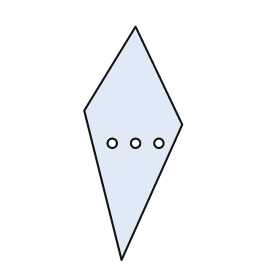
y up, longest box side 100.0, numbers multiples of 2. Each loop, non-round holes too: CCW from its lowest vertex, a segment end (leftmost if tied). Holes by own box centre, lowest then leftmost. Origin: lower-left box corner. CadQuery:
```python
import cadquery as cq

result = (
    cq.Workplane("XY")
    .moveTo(16.0, 0.0)
    .lineTo(42.0, 58.0)
    .lineTo(22.0, 100.0)
    .lineTo(0.0, 64.0)
    .close()
    .moveTo(12.0, 50.0)
    .circle(2.0)
    .moveTo(22.0, 50.0)
    .circle(2.0)
    .moveTo(32.0, 50.0)
    .circle(2.0)
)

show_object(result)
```